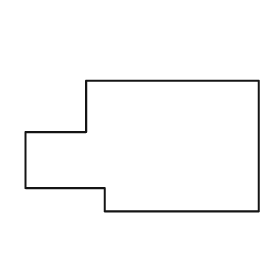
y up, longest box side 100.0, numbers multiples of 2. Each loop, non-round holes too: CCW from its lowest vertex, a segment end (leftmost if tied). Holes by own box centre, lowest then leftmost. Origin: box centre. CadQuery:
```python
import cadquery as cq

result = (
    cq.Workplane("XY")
    .moveTo(-16.0, -28.0)
    .lineTo(50.0, -28.0)
    .lineTo(50.0, 28.0)
    .lineTo(-24.0, 28.0)
    .lineTo(-24.0, 6.0)
    .lineTo(-50.0, 6.0)
    .lineTo(-50.0, -18.0)
    .lineTo(-16.0, -18.0)
    .close()
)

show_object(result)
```